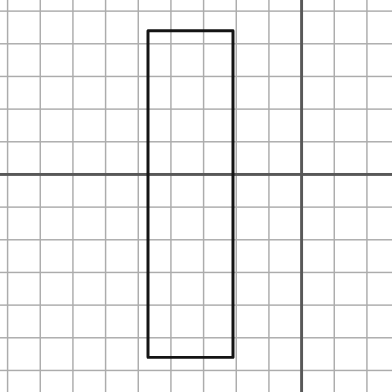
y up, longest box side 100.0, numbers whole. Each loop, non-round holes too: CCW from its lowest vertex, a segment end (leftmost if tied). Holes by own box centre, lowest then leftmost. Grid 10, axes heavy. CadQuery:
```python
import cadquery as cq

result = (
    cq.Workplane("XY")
    .moveTo(-47.0, -56.0)
    .lineTo(-21.0, -56.0)
    .lineTo(-21.0, 44.0)
    .lineTo(-47.0, 44.0)
    .close()
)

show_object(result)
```